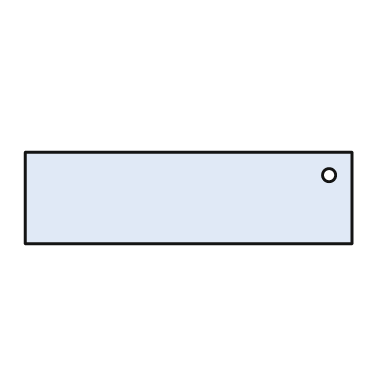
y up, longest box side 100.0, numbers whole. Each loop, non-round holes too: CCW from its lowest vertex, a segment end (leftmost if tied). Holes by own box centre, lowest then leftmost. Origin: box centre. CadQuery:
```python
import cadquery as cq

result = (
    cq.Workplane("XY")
    .moveTo(-50.0, -14.0)
    .lineTo(50.0, -14.0)
    .lineTo(50.0, 14.0)
    .lineTo(-50.0, 14.0)
    .close()
    .moveTo(43.0, 7.0)
    .circle(2.0)
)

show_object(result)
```